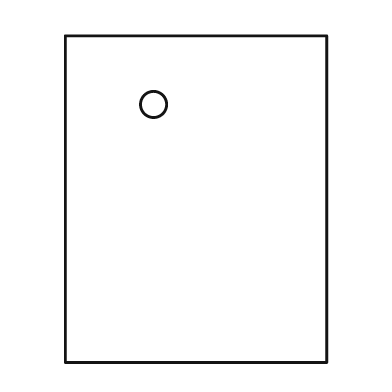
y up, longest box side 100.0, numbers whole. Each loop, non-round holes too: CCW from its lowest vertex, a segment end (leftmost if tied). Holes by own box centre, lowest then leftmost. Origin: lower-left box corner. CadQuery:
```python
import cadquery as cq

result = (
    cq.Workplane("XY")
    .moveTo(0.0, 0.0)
    .lineTo(80.0, 0.0)
    .lineTo(80.0, 100.0)
    .lineTo(0.0, 100.0)
    .close()
    .moveTo(27.0, 79.0)
    .circle(4.0)
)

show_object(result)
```